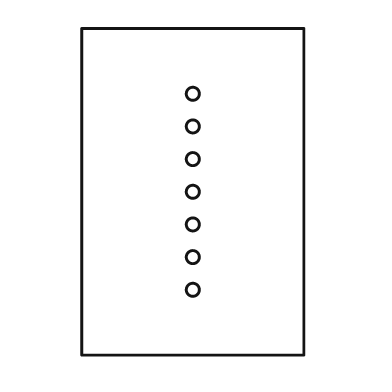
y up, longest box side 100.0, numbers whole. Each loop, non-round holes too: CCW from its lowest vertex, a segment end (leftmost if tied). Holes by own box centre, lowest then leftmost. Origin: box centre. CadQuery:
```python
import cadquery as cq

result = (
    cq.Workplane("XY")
    .moveTo(-34.0, -50.0)
    .lineTo(34.0, -50.0)
    .lineTo(34.0, 50.0)
    .lineTo(-34.0, 50.0)
    .close()
    .moveTo(0.0, -30.0)
    .circle(2.0)
    .moveTo(0.0, -20.0)
    .circle(2.0)
    .moveTo(0.0, -10.0)
    .circle(2.0)
    .moveTo(0.0, 0.0)
    .circle(2.0)
    .moveTo(0.0, 10.0)
    .circle(2.0)
    .moveTo(0.0, 20.0)
    .circle(2.0)
    .moveTo(0.0, 30.0)
    .circle(2.0)
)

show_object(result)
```